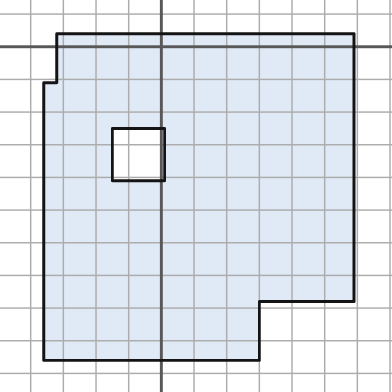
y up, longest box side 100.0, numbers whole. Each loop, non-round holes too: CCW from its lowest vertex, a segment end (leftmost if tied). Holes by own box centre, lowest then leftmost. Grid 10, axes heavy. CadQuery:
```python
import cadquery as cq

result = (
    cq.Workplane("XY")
    .moveTo(-36.0, -96.0)
    .lineTo(30.0, -96.0)
    .lineTo(30.0, -78.0)
    .lineTo(59.0, -78.0)
    .lineTo(59.0, 4.0)
    .lineTo(-32.0, 4.0)
    .lineTo(-32.0, -11.0)
    .lineTo(-36.0, -11.0)
    .close()
    .moveTo(-15.0, -41.0)
    .lineTo(1.0, -41.0)
    .lineTo(1.0, -25.0)
    .lineTo(-15.0, -25.0)
    .close()
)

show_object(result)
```